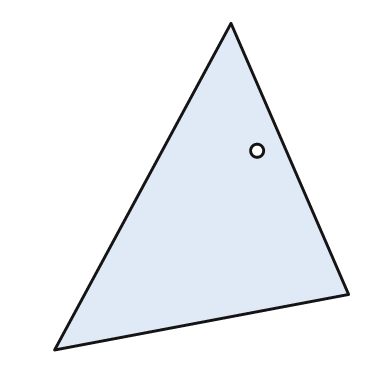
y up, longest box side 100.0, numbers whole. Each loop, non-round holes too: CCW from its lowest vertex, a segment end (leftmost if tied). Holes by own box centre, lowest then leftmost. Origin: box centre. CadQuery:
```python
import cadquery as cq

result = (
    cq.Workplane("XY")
    .moveTo(-45.0, -50.0)
    .lineTo(45.0, -33.0)
    .lineTo(9.0, 50.0)
    .close()
    .moveTo(17.0, 11.0)
    .circle(2.0)
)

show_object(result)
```